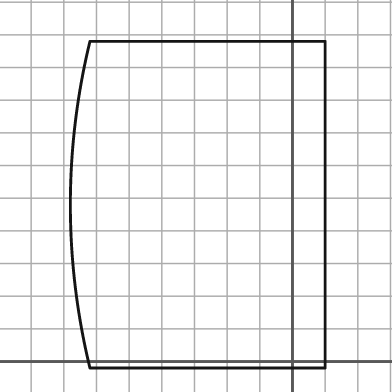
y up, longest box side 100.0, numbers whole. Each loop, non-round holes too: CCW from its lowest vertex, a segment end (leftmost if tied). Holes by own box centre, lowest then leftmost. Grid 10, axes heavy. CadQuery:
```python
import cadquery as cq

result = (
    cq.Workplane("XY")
    .moveTo(-62.0, -2.0)
    .lineTo(10.0, -2.0)
    .lineTo(10.0, 98.0)
    .lineTo(-62.0, 98.0)
    .threePointArc((-68.0, 48.0), (-62.0, -2.0))
    .close()
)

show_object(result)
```